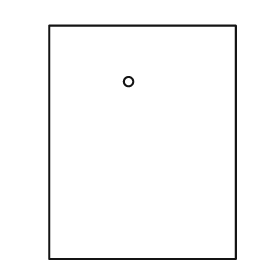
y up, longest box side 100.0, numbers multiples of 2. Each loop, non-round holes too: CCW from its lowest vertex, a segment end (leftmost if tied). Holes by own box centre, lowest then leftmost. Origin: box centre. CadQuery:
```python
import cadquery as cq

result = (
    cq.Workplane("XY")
    .moveTo(-40.0, -50.0)
    .lineTo(40.0, -50.0)
    .lineTo(40.0, 50.0)
    .lineTo(-40.0, 50.0)
    .close()
    .moveTo(-6.0, 26.0)
    .circle(2.0)
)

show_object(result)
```